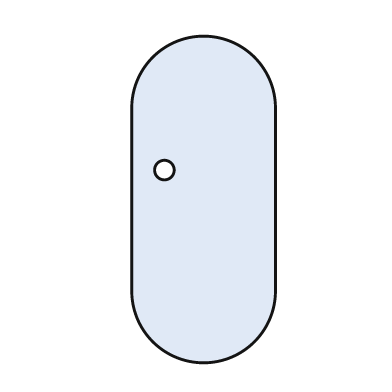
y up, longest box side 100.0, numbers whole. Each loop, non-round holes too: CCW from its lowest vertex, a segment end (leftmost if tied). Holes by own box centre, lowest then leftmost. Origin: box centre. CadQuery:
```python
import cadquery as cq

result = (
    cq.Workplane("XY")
    .moveTo(-22.0, -28.0)
    .threePointArc((0.0, -50.0), (22.0, -28.0))
    .lineTo(22.0, 28.0)
    .threePointArc((0.0, 50.0), (-22.0, 28.0))
    .close()
    .moveTo(-12.0, 9.0)
    .circle(3.0)
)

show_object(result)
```